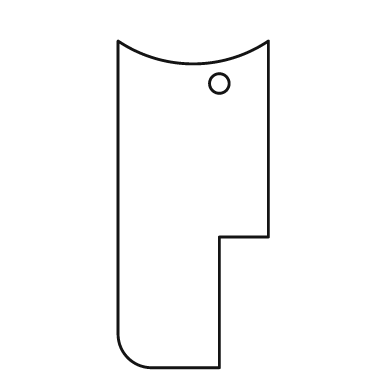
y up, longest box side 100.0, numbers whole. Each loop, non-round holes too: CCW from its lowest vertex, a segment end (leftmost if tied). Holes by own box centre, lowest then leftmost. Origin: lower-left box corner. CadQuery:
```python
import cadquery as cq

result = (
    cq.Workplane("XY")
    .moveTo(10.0, 0.0)
    .lineTo(31.0, 0.0)
    .lineTo(31.0, 40.0)
    .lineTo(46.0, 40.0)
    .lineTo(46.0, 100.0)
    .threePointArc((23.0, 93.0), (0.0, 100.0))
    .lineTo(0.0, 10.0)
    .threePointArc((3.0, 3.0), (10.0, 0.0))
    .close()
    .moveTo(31.0, 87.0)
    .circle(3.0)
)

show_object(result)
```